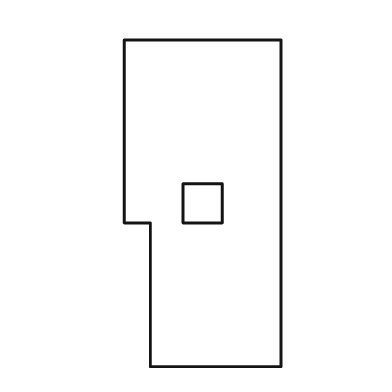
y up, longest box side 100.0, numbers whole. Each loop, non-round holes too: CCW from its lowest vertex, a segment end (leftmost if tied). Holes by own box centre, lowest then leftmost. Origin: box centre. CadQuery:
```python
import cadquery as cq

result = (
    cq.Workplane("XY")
    .moveTo(-16.0, -50.0)
    .lineTo(24.0, -50.0)
    .lineTo(24.0, 50.0)
    .lineTo(-24.0, 50.0)
    .lineTo(-24.0, -6.0)
    .lineTo(-16.0, -6.0)
    .close()
    .moveTo(-6.0, -6.0)
    .lineTo(6.0, -6.0)
    .lineTo(6.0, 6.0)
    .lineTo(-6.0, 6.0)
    .close()
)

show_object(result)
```